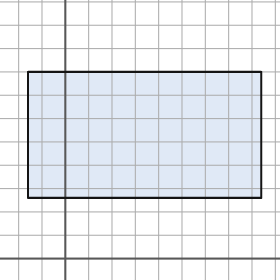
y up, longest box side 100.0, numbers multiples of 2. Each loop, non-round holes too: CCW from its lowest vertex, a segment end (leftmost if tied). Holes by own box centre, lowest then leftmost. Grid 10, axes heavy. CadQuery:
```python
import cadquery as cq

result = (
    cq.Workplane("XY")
    .moveTo(-16.0, 26.0)
    .lineTo(84.0, 26.0)
    .lineTo(84.0, 80.0)
    .lineTo(-16.0, 80.0)
    .close()
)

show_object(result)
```